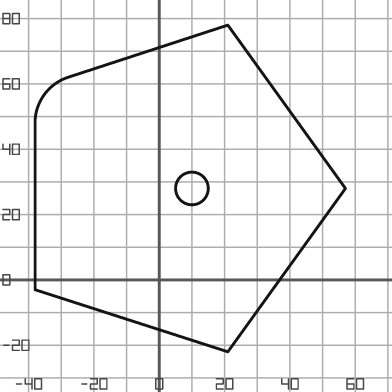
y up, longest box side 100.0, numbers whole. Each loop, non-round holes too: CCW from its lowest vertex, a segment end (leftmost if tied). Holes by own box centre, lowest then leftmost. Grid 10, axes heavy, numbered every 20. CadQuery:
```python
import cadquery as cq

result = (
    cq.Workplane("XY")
    .moveTo(21.0, -22.0)
    .lineTo(57.0, 28.0)
    .lineTo(21.0, 78.0)
    .lineTo(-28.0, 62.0)
    .threePointArc((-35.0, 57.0), (-38.0, 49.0))
    .lineTo(-38.0, -3.0)
    .close()
    .moveTo(10.0, 28.0)
    .circle(5.0)
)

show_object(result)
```